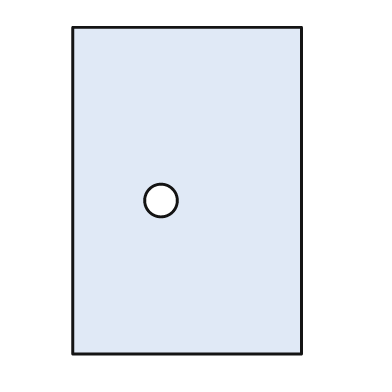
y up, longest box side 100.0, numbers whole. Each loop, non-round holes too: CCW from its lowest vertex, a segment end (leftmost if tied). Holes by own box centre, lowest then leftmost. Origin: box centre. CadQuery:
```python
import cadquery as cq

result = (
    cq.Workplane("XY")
    .moveTo(-35.0, -50.0)
    .lineTo(35.0, -50.0)
    .lineTo(35.0, 50.0)
    .lineTo(-35.0, 50.0)
    .close()
    .moveTo(-8.0, -3.0)
    .circle(5.0)
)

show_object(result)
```